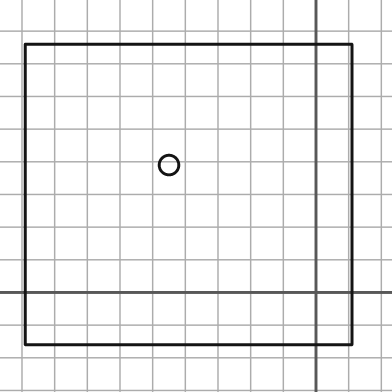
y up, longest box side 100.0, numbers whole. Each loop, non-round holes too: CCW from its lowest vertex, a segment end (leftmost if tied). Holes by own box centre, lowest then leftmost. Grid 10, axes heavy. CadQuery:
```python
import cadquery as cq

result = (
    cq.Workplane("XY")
    .moveTo(-89.0, -16.0)
    .lineTo(11.0, -16.0)
    .lineTo(11.0, 76.0)
    .lineTo(-89.0, 76.0)
    .close()
    .moveTo(-45.0, 39.0)
    .circle(3.0)
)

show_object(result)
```